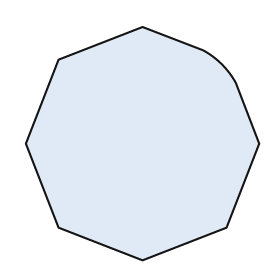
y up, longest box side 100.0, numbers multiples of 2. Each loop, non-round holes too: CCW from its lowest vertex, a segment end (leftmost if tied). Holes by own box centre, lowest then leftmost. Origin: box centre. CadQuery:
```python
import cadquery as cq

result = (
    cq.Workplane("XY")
    .moveTo(0.0, -50.0)
    .lineTo(36.0, -36.0)
    .lineTo(50.0, 0.0)
    .lineTo(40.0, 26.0)
    .threePointArc((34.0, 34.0), (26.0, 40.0))
    .lineTo(0.0, 50.0)
    .lineTo(-36.0, 36.0)
    .lineTo(-50.0, 0.0)
    .lineTo(-36.0, -36.0)
    .close()
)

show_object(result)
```